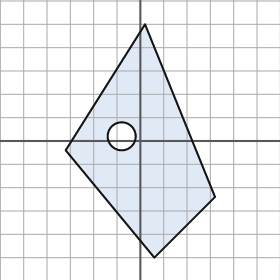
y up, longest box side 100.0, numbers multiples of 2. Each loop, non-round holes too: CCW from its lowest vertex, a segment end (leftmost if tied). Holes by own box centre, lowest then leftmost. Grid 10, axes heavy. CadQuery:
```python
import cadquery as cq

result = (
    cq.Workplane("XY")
    .moveTo(6.0, -50.0)
    .lineTo(32.0, -24.0)
    .lineTo(2.0, 50.0)
    .lineTo(-32.0, -4.0)
    .close()
    .moveTo(-8.0, 2.0)
    .circle(6.0)
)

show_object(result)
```